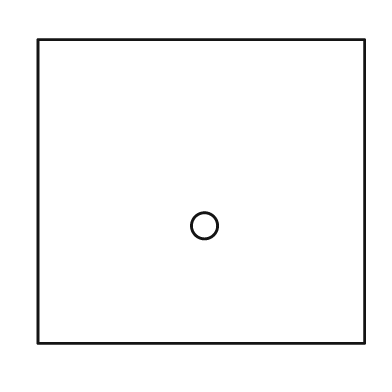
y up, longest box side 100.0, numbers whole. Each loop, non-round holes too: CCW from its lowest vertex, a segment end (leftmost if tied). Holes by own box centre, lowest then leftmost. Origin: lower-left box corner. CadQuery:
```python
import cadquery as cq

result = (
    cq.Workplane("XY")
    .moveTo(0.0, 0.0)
    .lineTo(100.0, 0.0)
    .lineTo(100.0, 93.0)
    .lineTo(0.0, 93.0)
    .close()
    .moveTo(51.0, 36.0)
    .circle(4.0)
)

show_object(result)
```